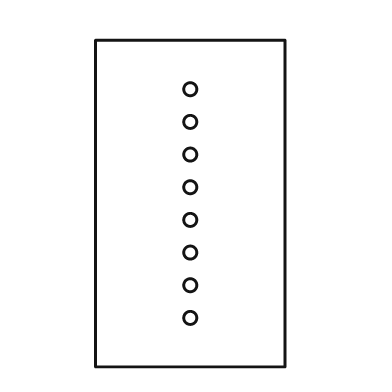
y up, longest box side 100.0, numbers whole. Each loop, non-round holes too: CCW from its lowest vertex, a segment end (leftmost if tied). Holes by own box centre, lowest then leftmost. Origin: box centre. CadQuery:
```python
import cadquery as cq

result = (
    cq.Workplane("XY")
    .moveTo(-29.0, -50.0)
    .lineTo(29.0, -50.0)
    .lineTo(29.0, 50.0)
    .lineTo(-29.0, 50.0)
    .close()
    .moveTo(0.0, -35.0)
    .circle(2.0)
    .moveTo(0.0, -25.0)
    .circle(2.0)
    .moveTo(0.0, -15.0)
    .circle(2.0)
    .moveTo(0.0, -5.0)
    .circle(2.0)
    .moveTo(0.0, 5.0)
    .circle(2.0)
    .moveTo(0.0, 15.0)
    .circle(2.0)
    .moveTo(0.0, 25.0)
    .circle(2.0)
    .moveTo(0.0, 35.0)
    .circle(2.0)
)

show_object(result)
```